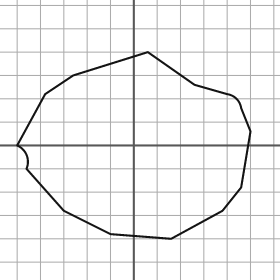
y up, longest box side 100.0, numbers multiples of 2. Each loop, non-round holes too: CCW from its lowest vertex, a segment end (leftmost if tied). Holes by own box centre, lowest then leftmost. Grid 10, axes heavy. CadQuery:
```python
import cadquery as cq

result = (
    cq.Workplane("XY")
    .moveTo(16.0, -40.0)
    .lineTo(38.0, -28.0)
    .lineTo(46.0, -18.0)
    .lineTo(50.0, 6.0)
    .lineTo(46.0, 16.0)
    .threePointArc((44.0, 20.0), (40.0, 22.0))
    .lineTo(26.0, 26.0)
    .lineTo(6.0, 40.0)
    .lineTo(-26.0, 30.0)
    .lineTo(-38.0, 22.0)
    .lineTo(-50.0, 0.0)
    .threePointArc((-46.0, -4.0), (-46.0, -10.0))
    .lineTo(-30.0, -28.0)
    .lineTo(-10.0, -38.0)
    .close()
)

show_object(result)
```